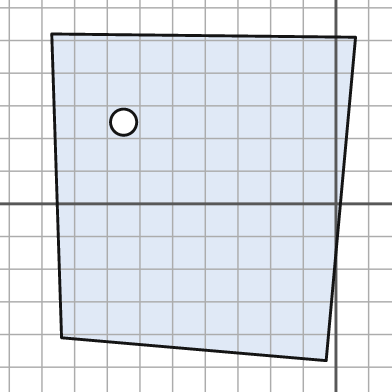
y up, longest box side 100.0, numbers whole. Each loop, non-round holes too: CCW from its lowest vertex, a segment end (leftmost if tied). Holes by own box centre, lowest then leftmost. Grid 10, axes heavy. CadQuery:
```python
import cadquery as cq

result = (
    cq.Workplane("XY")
    .moveTo(-3.0, -48.0)
    .lineTo(6.0, 51.0)
    .lineTo(-87.0, 52.0)
    .lineTo(-84.0, -41.0)
    .close()
    .moveTo(-65.0, 25.0)
    .circle(4.0)
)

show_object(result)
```